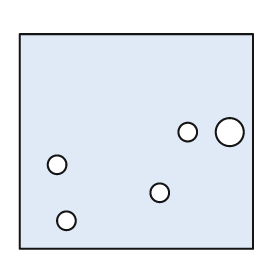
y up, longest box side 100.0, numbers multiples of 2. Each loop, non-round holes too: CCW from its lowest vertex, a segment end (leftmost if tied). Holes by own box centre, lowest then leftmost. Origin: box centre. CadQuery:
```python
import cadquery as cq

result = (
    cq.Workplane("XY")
    .moveTo(-50.0, -46.0)
    .lineTo(50.0, -46.0)
    .lineTo(50.0, 46.0)
    .lineTo(-50.0, 46.0)
    .close()
    .moveTo(-30.0, -34.0)
    .circle(4.0)
    .moveTo(10.0, -22.0)
    .circle(4.0)
    .moveTo(-34.0, -10.0)
    .circle(4.0)
    .moveTo(22.0, 4.0)
    .circle(4.0)
    .moveTo(40.0, 4.0)
    .circle(6.0)
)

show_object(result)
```